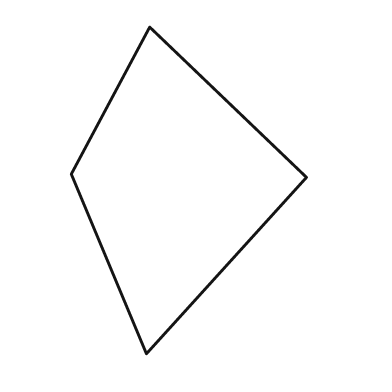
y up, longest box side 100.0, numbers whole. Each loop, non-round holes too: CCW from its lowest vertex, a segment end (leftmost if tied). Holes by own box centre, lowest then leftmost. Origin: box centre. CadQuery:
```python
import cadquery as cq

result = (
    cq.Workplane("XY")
    .moveTo(-13.0, -50.0)
    .lineTo(36.0, 4.0)
    .lineTo(-12.0, 50.0)
    .lineTo(-36.0, 5.0)
    .close()
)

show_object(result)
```